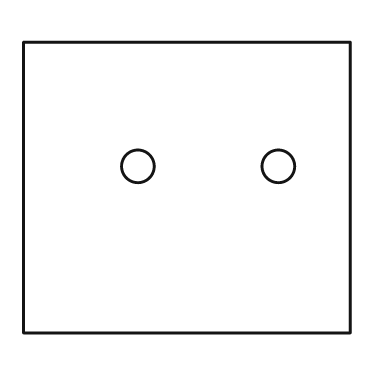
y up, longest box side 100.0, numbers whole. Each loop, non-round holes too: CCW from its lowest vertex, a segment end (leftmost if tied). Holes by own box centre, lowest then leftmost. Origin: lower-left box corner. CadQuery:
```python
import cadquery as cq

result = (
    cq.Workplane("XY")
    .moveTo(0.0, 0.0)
    .lineTo(100.0, 0.0)
    .lineTo(100.0, 89.0)
    .lineTo(0.0, 89.0)
    .close()
    .moveTo(35.0, 51.0)
    .circle(5.0)
    .moveTo(78.0, 51.0)
    .circle(5.0)
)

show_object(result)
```